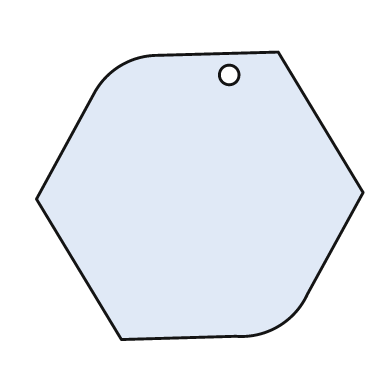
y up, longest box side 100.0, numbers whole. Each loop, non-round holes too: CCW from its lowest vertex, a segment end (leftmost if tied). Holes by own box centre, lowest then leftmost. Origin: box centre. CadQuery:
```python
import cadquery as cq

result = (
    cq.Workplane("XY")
    .moveTo(-24.0, -44.0)
    .lineTo(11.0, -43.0)
    .threePointArc((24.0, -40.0), (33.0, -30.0))
    .lineTo(50.0, 1.0)
    .lineTo(24.0, 44.0)
    .lineTo(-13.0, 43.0)
    .threePointArc((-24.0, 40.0), (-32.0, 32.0))
    .lineTo(-50.0, -1.0)
    .close()
    .moveTo(9.0, 37.0)
    .circle(3.0)
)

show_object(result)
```